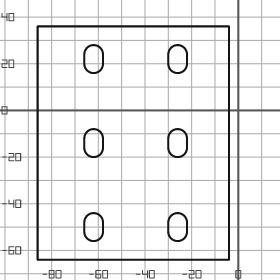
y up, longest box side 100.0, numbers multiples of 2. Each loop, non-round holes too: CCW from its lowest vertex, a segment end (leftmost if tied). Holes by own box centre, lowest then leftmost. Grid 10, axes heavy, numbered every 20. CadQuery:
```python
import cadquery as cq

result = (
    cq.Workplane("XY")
    .moveTo(-86.0, -64.0)
    .lineTo(-4.0, -64.0)
    .lineTo(-4.0, 36.0)
    .lineTo(-86.0, 36.0)
    .close()
    .moveTo(-66.0, -52.0)
    .threePointArc((-62.0, -56.0), (-58.0, -52.0))
    .lineTo(-58.0, -48.0)
    .threePointArc((-62.0, -44.0), (-66.0, -48.0))
    .close()
    .moveTo(-30.0, -52.0)
    .threePointArc((-26.0, -56.0), (-22.0, -52.0))
    .lineTo(-22.0, -48.0)
    .threePointArc((-26.0, -44.0), (-30.0, -48.0))
    .close()
    .moveTo(-66.0, -16.0)
    .threePointArc((-62.0, -20.0), (-58.0, -16.0))
    .lineTo(-58.0, -12.0)
    .threePointArc((-62.0, -8.0), (-66.0, -12.0))
    .close()
    .moveTo(-30.0, -16.0)
    .threePointArc((-26.0, -20.0), (-22.0, -16.0))
    .lineTo(-22.0, -12.0)
    .threePointArc((-26.0, -8.0), (-30.0, -12.0))
    .close()
    .moveTo(-66.0, 20.0)
    .threePointArc((-62.0, 16.0), (-58.0, 20.0))
    .lineTo(-58.0, 24.0)
    .threePointArc((-62.0, 28.0), (-66.0, 24.0))
    .close()
    .moveTo(-30.0, 20.0)
    .threePointArc((-26.0, 16.0), (-22.0, 20.0))
    .lineTo(-22.0, 24.0)
    .threePointArc((-26.0, 28.0), (-30.0, 24.0))
    .close()
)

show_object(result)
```